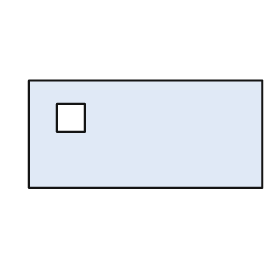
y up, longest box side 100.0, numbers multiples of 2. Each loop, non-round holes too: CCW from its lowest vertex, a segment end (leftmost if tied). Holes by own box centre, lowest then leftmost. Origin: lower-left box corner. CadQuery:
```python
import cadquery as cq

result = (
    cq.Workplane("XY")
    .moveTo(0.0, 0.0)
    .lineTo(100.0, 0.0)
    .lineTo(100.0, 46.0)
    .lineTo(0.0, 46.0)
    .close()
    .moveTo(12.0, 24.0)
    .lineTo(24.0, 24.0)
    .lineTo(24.0, 36.0)
    .lineTo(12.0, 36.0)
    .close()
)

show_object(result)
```